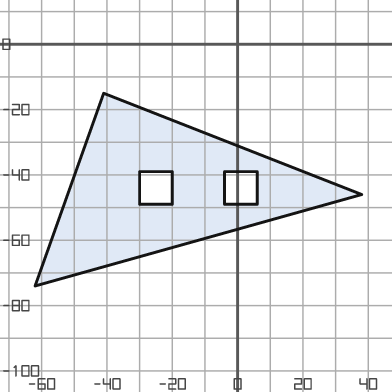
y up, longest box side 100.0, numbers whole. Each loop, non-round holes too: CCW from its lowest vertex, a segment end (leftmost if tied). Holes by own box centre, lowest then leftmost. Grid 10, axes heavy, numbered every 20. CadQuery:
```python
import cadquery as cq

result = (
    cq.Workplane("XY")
    .moveTo(-62.0, -74.0)
    .lineTo(38.0, -46.0)
    .lineTo(-41.0, -15.0)
    .close()
    .moveTo(-30.0, -49.0)
    .lineTo(-20.0, -49.0)
    .lineTo(-20.0, -39.0)
    .lineTo(-30.0, -39.0)
    .close()
    .moveTo(-4.0, -49.0)
    .lineTo(6.0, -49.0)
    .lineTo(6.0, -39.0)
    .lineTo(-4.0, -39.0)
    .close()
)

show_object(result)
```